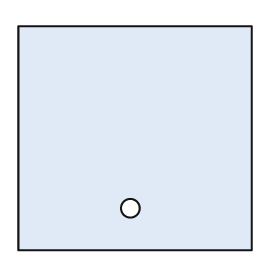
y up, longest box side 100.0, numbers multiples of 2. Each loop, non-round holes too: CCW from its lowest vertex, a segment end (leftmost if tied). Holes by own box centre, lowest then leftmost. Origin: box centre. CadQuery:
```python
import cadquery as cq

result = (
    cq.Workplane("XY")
    .moveTo(-50.0, -48.0)
    .lineTo(50.0, -48.0)
    .lineTo(50.0, 48.0)
    .lineTo(-50.0, 48.0)
    .close()
    .moveTo(-2.0, -30.0)
    .circle(4.0)
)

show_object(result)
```